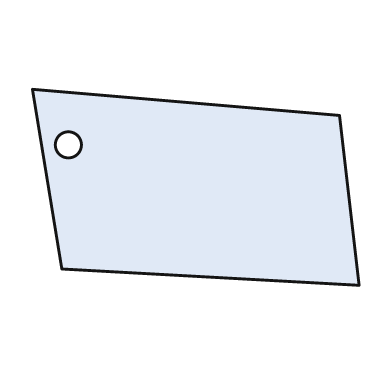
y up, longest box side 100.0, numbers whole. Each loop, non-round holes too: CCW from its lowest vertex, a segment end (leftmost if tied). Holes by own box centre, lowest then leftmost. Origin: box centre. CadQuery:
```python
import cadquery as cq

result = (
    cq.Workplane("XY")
    .moveTo(50.0, -30.0)
    .lineTo(44.0, 22.0)
    .lineTo(-50.0, 30.0)
    .lineTo(-41.0, -25.0)
    .close()
    .moveTo(-39.0, 13.0)
    .circle(4.0)
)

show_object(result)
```